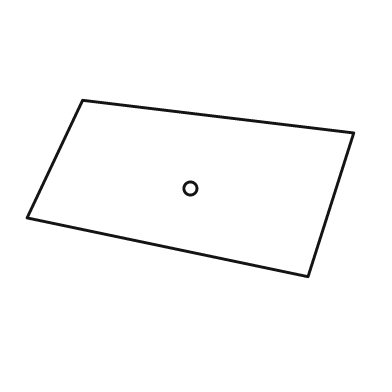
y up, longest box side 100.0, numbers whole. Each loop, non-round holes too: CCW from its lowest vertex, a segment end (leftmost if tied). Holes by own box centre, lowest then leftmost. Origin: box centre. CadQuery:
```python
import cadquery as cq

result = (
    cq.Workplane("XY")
    .moveTo(36.0, -27.0)
    .lineTo(50.0, 17.0)
    .lineTo(-33.0, 27.0)
    .lineTo(-50.0, -9.0)
    .close()
    .moveTo(0.0, 0.0)
    .circle(2.0)
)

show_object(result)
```